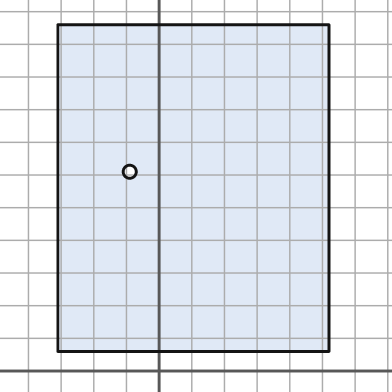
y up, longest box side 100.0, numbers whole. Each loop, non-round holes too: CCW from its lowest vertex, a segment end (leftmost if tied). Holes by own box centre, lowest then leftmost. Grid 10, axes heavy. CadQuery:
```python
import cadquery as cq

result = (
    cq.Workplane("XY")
    .moveTo(-31.0, 6.0)
    .lineTo(52.0, 6.0)
    .lineTo(52.0, 106.0)
    .lineTo(-31.0, 106.0)
    .close()
    .moveTo(-9.0, 61.0)
    .circle(2.0)
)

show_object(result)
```